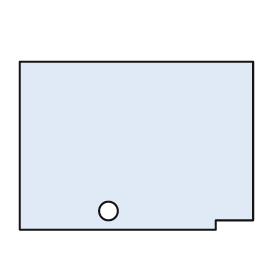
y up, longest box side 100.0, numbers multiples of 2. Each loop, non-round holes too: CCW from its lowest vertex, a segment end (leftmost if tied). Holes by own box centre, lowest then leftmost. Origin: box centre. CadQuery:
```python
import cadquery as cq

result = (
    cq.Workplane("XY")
    .moveTo(-50.0, -36.0)
    .lineTo(34.0, -36.0)
    .lineTo(34.0, -32.0)
    .lineTo(50.0, -32.0)
    .lineTo(50.0, 36.0)
    .lineTo(-50.0, 36.0)
    .close()
    .moveTo(-12.0, -28.0)
    .circle(4.0)
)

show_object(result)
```